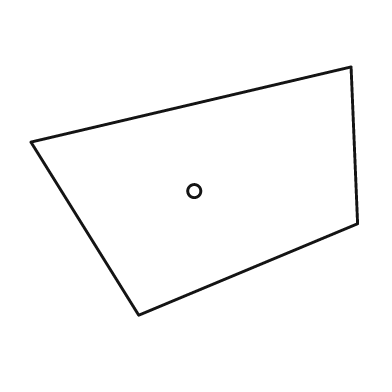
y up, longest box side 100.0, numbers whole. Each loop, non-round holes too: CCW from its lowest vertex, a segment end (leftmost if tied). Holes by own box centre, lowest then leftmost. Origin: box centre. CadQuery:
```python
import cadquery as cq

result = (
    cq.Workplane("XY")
    .moveTo(-17.0, -38.0)
    .lineTo(50.0, -10.0)
    .lineTo(48.0, 38.0)
    .lineTo(-50.0, 15.0)
    .close()
    .moveTo(0.0, 0.0)
    .circle(2.0)
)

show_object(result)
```